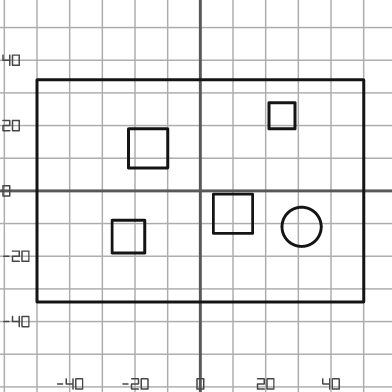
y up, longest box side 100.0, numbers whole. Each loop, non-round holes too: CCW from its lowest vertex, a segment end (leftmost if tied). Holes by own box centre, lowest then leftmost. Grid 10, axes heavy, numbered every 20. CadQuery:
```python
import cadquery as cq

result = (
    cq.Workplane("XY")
    .moveTo(-50.0, -34.0)
    .lineTo(50.0, -34.0)
    .lineTo(50.0, 34.0)
    .lineTo(-50.0, 34.0)
    .close()
    .moveTo(-27.0, -19.0)
    .lineTo(-17.0, -19.0)
    .lineTo(-17.0, -9.0)
    .lineTo(-27.0, -9.0)
    .close()
    .moveTo(31.0, -11.0)
    .circle(6.0)
    .moveTo(4.0, -13.0)
    .lineTo(16.0, -13.0)
    .lineTo(16.0, -1.0)
    .lineTo(4.0, -1.0)
    .close()
    .moveTo(-22.0, 7.0)
    .lineTo(-10.0, 7.0)
    .lineTo(-10.0, 19.0)
    .lineTo(-22.0, 19.0)
    .close()
    .moveTo(21.0, 19.0)
    .lineTo(29.0, 19.0)
    .lineTo(29.0, 27.0)
    .lineTo(21.0, 27.0)
    .close()
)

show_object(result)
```